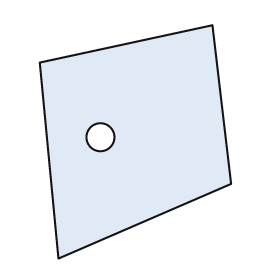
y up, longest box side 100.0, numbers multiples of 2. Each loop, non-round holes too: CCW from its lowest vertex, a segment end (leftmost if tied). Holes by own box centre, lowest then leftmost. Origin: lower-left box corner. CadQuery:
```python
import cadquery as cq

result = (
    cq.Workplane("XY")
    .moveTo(8.0, 0.0)
    .lineTo(82.0, 32.0)
    .lineTo(74.0, 100.0)
    .lineTo(0.0, 84.0)
    .close()
    .moveTo(26.0, 52.0)
    .circle(6.0)
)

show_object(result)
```